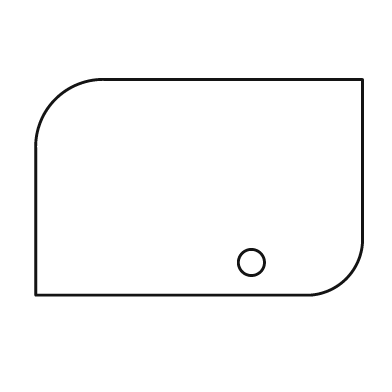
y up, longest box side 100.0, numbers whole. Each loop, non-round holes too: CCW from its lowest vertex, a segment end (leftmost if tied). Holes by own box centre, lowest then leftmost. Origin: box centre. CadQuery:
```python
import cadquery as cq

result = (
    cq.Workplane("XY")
    .moveTo(-50.0, -33.0)
    .lineTo(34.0, -33.0)
    .threePointArc((45.0, -28.0), (50.0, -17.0))
    .lineTo(50.0, 33.0)
    .lineTo(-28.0, 33.0)
    .threePointArc((-44.0, 27.0), (-50.0, 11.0))
    .close()
    .moveTo(16.0, -23.0)
    .circle(4.0)
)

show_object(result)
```